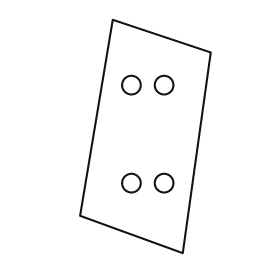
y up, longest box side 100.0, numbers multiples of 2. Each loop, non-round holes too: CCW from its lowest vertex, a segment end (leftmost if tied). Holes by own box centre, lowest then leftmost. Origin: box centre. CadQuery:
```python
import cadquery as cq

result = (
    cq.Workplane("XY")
    .moveTo(16.0, -50.0)
    .lineTo(28.0, 36.0)
    .lineTo(-14.0, 50.0)
    .lineTo(-28.0, -34.0)
    .close()
    .moveTo(-6.0, -20.0)
    .circle(4.0)
    .moveTo(8.0, -20.0)
    .circle(4.0)
    .moveTo(-6.0, 22.0)
    .circle(4.0)
    .moveTo(8.0, 22.0)
    .circle(4.0)
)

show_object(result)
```